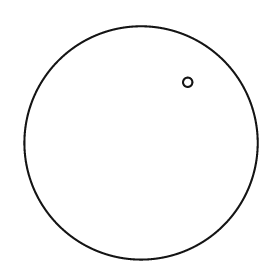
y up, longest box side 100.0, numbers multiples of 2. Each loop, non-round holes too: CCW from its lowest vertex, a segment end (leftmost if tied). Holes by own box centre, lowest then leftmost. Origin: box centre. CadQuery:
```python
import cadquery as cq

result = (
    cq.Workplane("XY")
    .moveTo(0.0, 0.0)
    .circle(50.0)
    .moveTo(20.0, 26.0)
    .circle(2.0)
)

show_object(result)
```